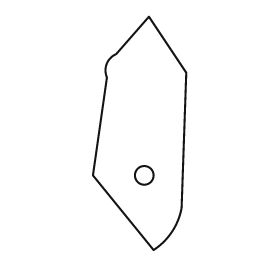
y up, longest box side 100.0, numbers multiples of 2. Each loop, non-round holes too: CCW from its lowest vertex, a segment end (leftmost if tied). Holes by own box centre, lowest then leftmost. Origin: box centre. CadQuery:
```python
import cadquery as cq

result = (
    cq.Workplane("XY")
    .moveTo(6.0, -50.0)
    .threePointArc((14.0, -42.0), (18.0, -32.0))
    .lineTo(20.0, 26.0)
    .lineTo(4.0, 50.0)
    .lineTo(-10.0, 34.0)
    .threePointArc((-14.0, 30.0), (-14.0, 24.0))
    .lineTo(-20.0, -18.0)
    .close()
    .moveTo(2.0, -18.0)
    .circle(4.0)
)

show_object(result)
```